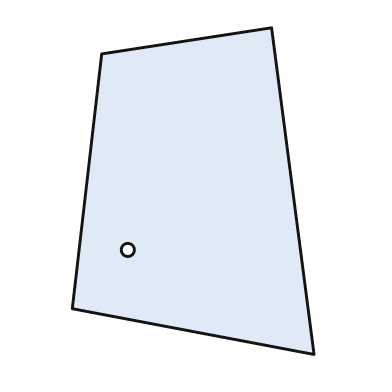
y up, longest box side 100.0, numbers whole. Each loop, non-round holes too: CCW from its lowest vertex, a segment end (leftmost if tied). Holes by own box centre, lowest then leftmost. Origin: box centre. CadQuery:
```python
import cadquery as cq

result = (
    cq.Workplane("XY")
    .moveTo(37.0, -50.0)
    .lineTo(24.0, 50.0)
    .lineTo(-28.0, 42.0)
    .lineTo(-37.0, -36.0)
    .close()
    .moveTo(-20.0, -18.0)
    .circle(2.0)
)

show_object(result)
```